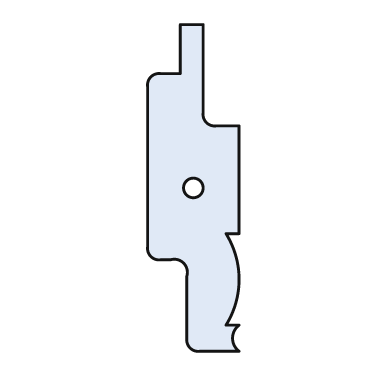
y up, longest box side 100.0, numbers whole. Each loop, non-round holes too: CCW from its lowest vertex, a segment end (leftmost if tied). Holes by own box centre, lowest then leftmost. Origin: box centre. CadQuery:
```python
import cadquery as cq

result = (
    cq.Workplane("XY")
    .moveTo(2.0, -50.0)
    .lineTo(14.0, -50.0)
    .threePointArc((12.0, -46.0), (14.0, -42.0))
    .lineTo(10.0, -42.0)
    .threePointArc((14.0, -28.0), (10.0, -14.0))
    .lineTo(14.0, -14.0)
    .lineTo(14.0, 19.0)
    .lineTo(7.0, 19.0)
    .threePointArc((4.0, 20.0), (3.0, 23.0))
    .lineTo(3.0, 50.0)
    .lineTo(-4.0, 50.0)
    .lineTo(-4.0, 35.0)
    .lineTo(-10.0, 35.0)
    .threePointArc((-13.0, 34.0), (-14.0, 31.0))
    .lineTo(-14.0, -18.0)
    .threePointArc((-13.0, -21.0), (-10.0, -22.0))
    .lineTo(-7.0, -22.0)
    .threePointArc((-3.0, -23.0), (-2.0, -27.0))
    .lineTo(-2.0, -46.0)
    .threePointArc((-1.0, -49.0), (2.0, -50.0))
    .close()
    .moveTo(0.0, 0.0)
    .circle(3.0)
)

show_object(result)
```